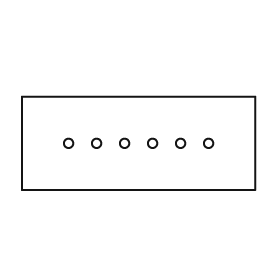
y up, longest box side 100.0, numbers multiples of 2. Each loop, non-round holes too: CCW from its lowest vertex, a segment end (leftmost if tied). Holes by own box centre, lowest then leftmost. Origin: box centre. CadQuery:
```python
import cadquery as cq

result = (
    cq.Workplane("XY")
    .moveTo(-50.0, -20.0)
    .lineTo(50.0, -20.0)
    .lineTo(50.0, 20.0)
    .lineTo(-50.0, 20.0)
    .close()
    .moveTo(-30.0, 0.0)
    .circle(2.0)
    .moveTo(-18.0, 0.0)
    .circle(2.0)
    .moveTo(-6.0, 0.0)
    .circle(2.0)
    .moveTo(6.0, 0.0)
    .circle(2.0)
    .moveTo(18.0, 0.0)
    .circle(2.0)
    .moveTo(30.0, 0.0)
    .circle(2.0)
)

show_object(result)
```